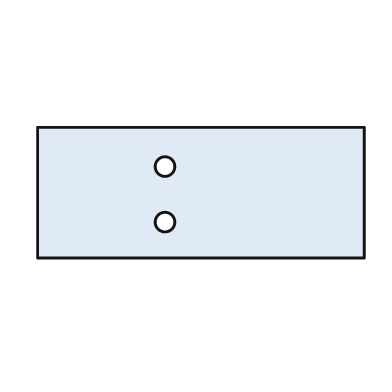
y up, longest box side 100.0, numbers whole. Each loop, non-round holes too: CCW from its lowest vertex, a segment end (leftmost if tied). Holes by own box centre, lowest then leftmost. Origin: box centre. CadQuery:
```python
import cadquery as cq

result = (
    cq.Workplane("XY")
    .moveTo(-50.0, -20.0)
    .lineTo(50.0, -20.0)
    .lineTo(50.0, 20.0)
    .lineTo(-50.0, 20.0)
    .close()
    .moveTo(-11.0, -9.0)
    .circle(3.0)
    .moveTo(-11.0, 8.0)
    .circle(3.0)
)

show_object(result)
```